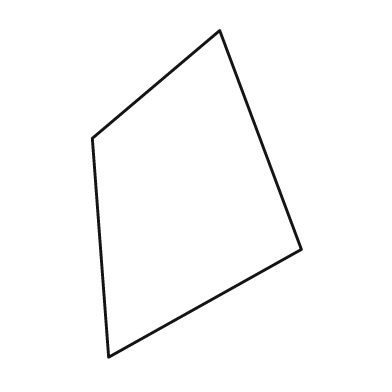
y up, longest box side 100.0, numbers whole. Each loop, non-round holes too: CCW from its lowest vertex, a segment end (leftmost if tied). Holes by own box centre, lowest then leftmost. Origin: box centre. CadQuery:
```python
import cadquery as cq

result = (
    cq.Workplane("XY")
    .moveTo(-27.0, -50.0)
    .lineTo(32.0, -17.0)
    .lineTo(7.0, 50.0)
    .lineTo(-32.0, 17.0)
    .close()
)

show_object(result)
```